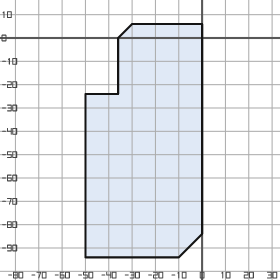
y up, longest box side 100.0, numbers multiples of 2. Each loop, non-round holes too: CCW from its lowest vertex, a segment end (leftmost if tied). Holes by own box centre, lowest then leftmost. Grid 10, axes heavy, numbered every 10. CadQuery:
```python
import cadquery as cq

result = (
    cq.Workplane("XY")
    .moveTo(-50.0, -94.0)
    .lineTo(-10.0, -94.0)
    .lineTo(0.0, -84.0)
    .lineTo(0.0, 6.0)
    .lineTo(-30.0, 6.0)
    .lineTo(-36.0, 0.0)
    .lineTo(-36.0, -24.0)
    .lineTo(-50.0, -24.0)
    .close()
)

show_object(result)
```